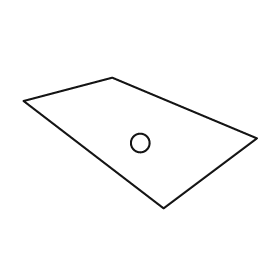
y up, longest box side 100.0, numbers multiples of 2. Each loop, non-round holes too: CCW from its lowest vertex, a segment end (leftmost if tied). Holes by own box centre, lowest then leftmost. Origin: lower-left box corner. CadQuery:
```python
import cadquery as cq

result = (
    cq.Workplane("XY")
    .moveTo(60.0, 0.0)
    .lineTo(100.0, 30.0)
    .lineTo(38.0, 56.0)
    .lineTo(0.0, 46.0)
    .close()
    .moveTo(50.0, 28.0)
    .circle(4.0)
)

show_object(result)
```